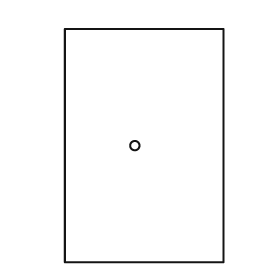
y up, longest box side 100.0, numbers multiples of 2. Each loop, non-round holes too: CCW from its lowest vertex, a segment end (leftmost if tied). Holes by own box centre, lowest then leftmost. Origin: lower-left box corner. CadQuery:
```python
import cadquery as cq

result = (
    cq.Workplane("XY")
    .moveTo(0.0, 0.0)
    .lineTo(68.0, 0.0)
    .lineTo(68.0, 100.0)
    .lineTo(0.0, 100.0)
    .close()
    .moveTo(30.0, 50.0)
    .circle(2.0)
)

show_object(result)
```